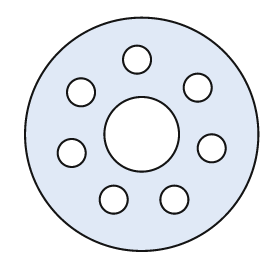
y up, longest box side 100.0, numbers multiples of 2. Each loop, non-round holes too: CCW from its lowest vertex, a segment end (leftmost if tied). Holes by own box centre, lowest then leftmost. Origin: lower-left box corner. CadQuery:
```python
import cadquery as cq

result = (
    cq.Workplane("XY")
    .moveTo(50.0, 50.0)
    .circle(50.0)
    .moveTo(38.0, 22.0)
    .circle(6.0)
    .moveTo(64.0, 22.0)
    .circle(6.0)
    .moveTo(20.0, 42.0)
    .circle(6.0)
    .moveTo(80.0, 44.0)
    .circle(6.0)
    .moveTo(50.0, 50.0)
    .circle(16.0)
    .moveTo(24.0, 68.0)
    .circle(6.0)
    .moveTo(74.0, 70.0)
    .circle(6.0)
    .moveTo(48.0, 82.0)
    .circle(6.0)
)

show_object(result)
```